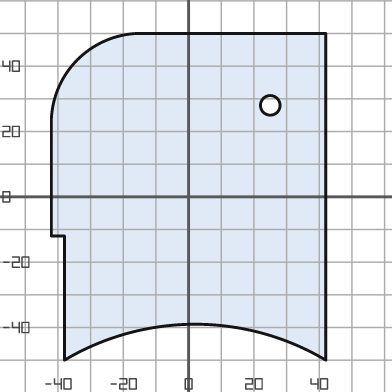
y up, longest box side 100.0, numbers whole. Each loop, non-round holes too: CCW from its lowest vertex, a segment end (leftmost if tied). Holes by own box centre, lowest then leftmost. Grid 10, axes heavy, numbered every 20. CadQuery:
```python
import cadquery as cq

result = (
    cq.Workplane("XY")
    .moveTo(-38.0, -50.0)
    .threePointArc((2.0, -39.0), (42.0, -50.0))
    .lineTo(42.0, 50.0)
    .lineTo(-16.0, 50.0)
    .threePointArc((-34.0, 42.0), (-42.0, 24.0))
    .lineTo(-42.0, -12.0)
    .lineTo(-38.0, -12.0)
    .close()
    .moveTo(25.0, 28.0)
    .circle(3.0)
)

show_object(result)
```